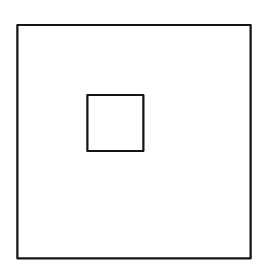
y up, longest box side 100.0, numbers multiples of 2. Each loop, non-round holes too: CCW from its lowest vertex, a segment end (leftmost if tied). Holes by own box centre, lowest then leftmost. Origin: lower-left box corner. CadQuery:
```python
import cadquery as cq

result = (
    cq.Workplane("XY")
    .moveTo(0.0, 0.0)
    .lineTo(100.0, 0.0)
    .lineTo(100.0, 100.0)
    .lineTo(0.0, 100.0)
    .close()
    .moveTo(30.0, 46.0)
    .lineTo(54.0, 46.0)
    .lineTo(54.0, 70.0)
    .lineTo(30.0, 70.0)
    .close()
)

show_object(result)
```